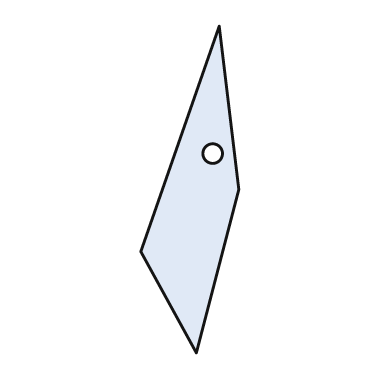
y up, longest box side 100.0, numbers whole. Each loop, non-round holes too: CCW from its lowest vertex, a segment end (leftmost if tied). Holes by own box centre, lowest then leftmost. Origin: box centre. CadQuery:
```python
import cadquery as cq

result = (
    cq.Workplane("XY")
    .moveTo(2.0, -50.0)
    .lineTo(15.0, 0.0)
    .lineTo(9.0, 50.0)
    .lineTo(-15.0, -19.0)
    .close()
    .moveTo(7.0, 11.0)
    .circle(3.0)
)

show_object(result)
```